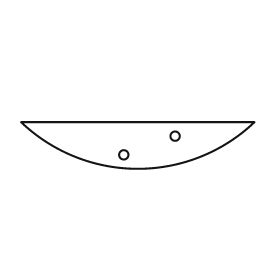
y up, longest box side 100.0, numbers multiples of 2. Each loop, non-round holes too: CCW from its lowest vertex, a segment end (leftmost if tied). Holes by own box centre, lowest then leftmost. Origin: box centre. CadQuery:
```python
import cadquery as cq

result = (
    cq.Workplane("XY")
    .moveTo(-50.0, 10.0)
    .threePointArc((0.0, -10.0), (50.0, 10.0))
    .close()
    .moveTo(-6.0, -4.0)
    .circle(2.0)
    .moveTo(16.0, 4.0)
    .circle(2.0)
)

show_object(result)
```